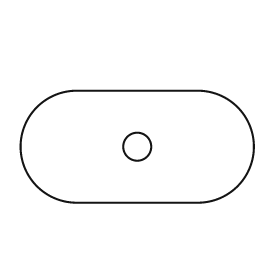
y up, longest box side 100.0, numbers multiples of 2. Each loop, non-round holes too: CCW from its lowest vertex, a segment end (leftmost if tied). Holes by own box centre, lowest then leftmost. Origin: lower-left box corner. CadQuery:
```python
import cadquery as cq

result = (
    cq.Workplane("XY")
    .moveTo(24.0, 0.0)
    .lineTo(76.0, 0.0)
    .threePointArc((100.0, 24.0), (76.0, 48.0))
    .lineTo(24.0, 48.0)
    .threePointArc((0.0, 24.0), (24.0, 0.0))
    .close()
    .moveTo(50.0, 24.0)
    .circle(6.0)
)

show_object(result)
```